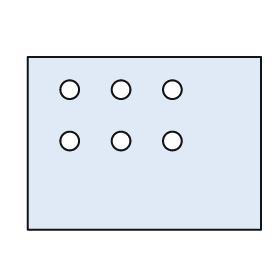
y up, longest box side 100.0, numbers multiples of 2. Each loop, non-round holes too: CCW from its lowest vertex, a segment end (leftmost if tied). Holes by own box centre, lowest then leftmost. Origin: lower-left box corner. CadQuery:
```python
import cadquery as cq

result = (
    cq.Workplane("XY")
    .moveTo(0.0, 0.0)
    .lineTo(100.0, 0.0)
    .lineTo(100.0, 74.0)
    .lineTo(0.0, 74.0)
    .close()
    .moveTo(18.0, 38.0)
    .circle(4.0)
    .moveTo(40.0, 38.0)
    .circle(4.0)
    .moveTo(62.0, 38.0)
    .circle(4.0)
    .moveTo(18.0, 60.0)
    .circle(4.0)
    .moveTo(40.0, 60.0)
    .circle(4.0)
    .moveTo(62.0, 60.0)
    .circle(4.0)
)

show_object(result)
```